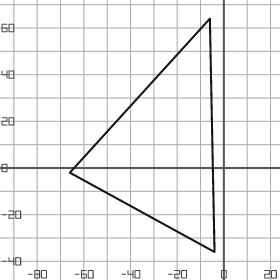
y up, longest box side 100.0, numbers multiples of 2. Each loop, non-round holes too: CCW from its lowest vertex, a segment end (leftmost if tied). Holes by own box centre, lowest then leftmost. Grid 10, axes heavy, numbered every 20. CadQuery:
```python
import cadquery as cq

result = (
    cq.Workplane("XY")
    .moveTo(-4.0, -36.0)
    .lineTo(-6.0, 64.0)
    .lineTo(-66.0, -2.0)
    .close()
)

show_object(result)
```